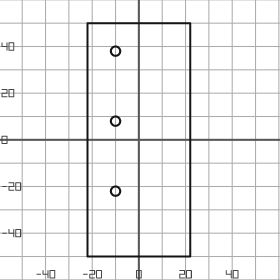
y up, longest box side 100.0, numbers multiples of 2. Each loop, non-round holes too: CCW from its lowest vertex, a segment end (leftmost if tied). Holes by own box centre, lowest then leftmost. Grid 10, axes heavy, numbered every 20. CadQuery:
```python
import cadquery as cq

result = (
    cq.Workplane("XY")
    .moveTo(-22.0, -50.0)
    .lineTo(22.0, -50.0)
    .lineTo(22.0, 50.0)
    .lineTo(-22.0, 50.0)
    .close()
    .moveTo(-10.0, -22.0)
    .circle(2.0)
    .moveTo(-10.0, 8.0)
    .circle(2.0)
    .moveTo(-10.0, 38.0)
    .circle(2.0)
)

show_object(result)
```